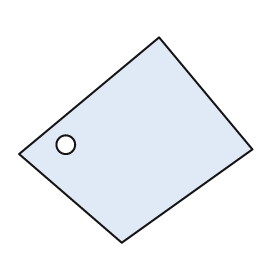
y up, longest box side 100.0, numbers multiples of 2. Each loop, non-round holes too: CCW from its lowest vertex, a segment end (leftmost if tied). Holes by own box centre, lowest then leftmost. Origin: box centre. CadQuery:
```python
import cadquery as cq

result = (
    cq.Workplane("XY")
    .moveTo(-6.0, -44.0)
    .lineTo(50.0, -4.0)
    .lineTo(10.0, 44.0)
    .lineTo(-50.0, -6.0)
    .close()
    .moveTo(-30.0, -2.0)
    .circle(4.0)
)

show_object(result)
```